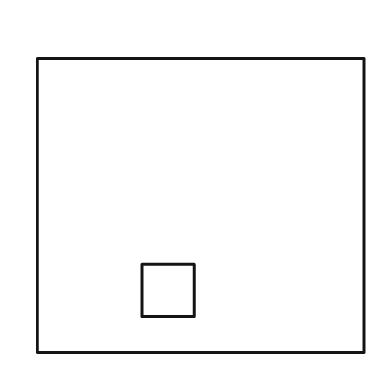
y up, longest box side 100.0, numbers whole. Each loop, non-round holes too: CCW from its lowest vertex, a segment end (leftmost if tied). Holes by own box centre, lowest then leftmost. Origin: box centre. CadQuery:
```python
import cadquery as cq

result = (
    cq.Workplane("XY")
    .moveTo(-50.0, -45.0)
    .lineTo(50.0, -45.0)
    .lineTo(50.0, 45.0)
    .lineTo(-50.0, 45.0)
    .close()
    .moveTo(-18.0, -34.0)
    .lineTo(-2.0, -34.0)
    .lineTo(-2.0, -18.0)
    .lineTo(-18.0, -18.0)
    .close()
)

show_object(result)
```